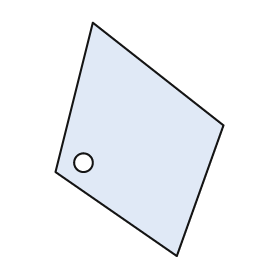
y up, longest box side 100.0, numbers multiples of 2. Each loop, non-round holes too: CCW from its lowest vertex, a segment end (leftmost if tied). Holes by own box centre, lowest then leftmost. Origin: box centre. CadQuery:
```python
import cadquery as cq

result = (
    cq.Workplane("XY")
    .moveTo(16.0, -50.0)
    .lineTo(36.0, 6.0)
    .lineTo(-20.0, 50.0)
    .lineTo(-36.0, -14.0)
    .close()
    .moveTo(-24.0, -10.0)
    .circle(4.0)
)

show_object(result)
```